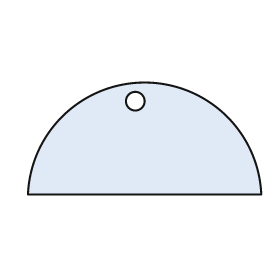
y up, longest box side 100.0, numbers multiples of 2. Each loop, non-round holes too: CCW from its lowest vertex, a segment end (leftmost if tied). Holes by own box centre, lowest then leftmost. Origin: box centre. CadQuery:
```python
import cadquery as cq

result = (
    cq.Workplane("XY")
    .moveTo(-50.0, -24.0)
    .lineTo(50.0, -24.0)
    .threePointArc((0.0, 24.0), (-50.0, -24.0))
    .close()
    .moveTo(-4.0, 16.0)
    .circle(4.0)
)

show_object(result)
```